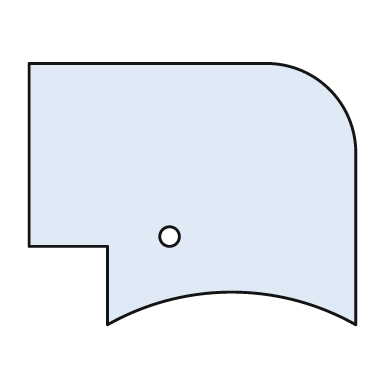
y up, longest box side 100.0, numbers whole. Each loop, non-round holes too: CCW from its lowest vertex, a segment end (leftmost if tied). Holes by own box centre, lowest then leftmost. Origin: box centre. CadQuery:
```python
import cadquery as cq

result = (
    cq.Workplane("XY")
    .moveTo(-26.0, -40.0)
    .threePointArc((12.0, -30.0), (50.0, -40.0))
    .lineTo(50.0, 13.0)
    .threePointArc((42.0, 32.0), (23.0, 40.0))
    .lineTo(-50.0, 40.0)
    .lineTo(-50.0, -16.0)
    .lineTo(-26.0, -16.0)
    .close()
    .moveTo(-7.0, -13.0)
    .circle(3.0)
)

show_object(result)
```